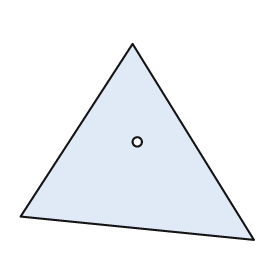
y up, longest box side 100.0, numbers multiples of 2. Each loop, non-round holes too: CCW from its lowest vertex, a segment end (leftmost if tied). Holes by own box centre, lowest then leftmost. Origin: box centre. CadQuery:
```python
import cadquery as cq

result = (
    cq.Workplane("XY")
    .moveTo(50.0, -42.0)
    .lineTo(-2.0, 42.0)
    .lineTo(-50.0, -32.0)
    .close()
    .moveTo(0.0, 0.0)
    .circle(2.0)
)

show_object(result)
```